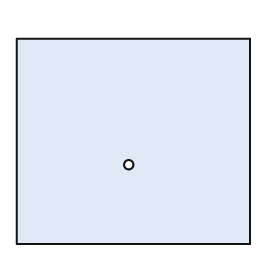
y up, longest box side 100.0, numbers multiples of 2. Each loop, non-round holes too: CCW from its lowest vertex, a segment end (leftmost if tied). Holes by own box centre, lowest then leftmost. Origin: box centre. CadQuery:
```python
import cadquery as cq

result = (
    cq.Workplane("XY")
    .moveTo(-50.0, -44.0)
    .lineTo(50.0, -44.0)
    .lineTo(50.0, 44.0)
    .lineTo(-50.0, 44.0)
    .close()
    .moveTo(-2.0, -10.0)
    .circle(2.0)
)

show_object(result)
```